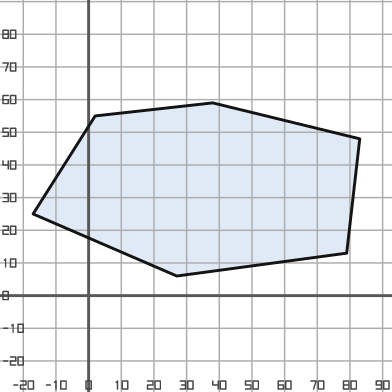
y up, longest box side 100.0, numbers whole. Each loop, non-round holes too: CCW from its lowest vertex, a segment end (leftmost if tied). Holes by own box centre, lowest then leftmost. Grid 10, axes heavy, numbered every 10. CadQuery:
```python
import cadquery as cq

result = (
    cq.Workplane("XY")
    .moveTo(27.0, 6.0)
    .lineTo(79.0, 13.0)
    .lineTo(83.0, 48.0)
    .lineTo(38.0, 59.0)
    .lineTo(2.0, 55.0)
    .lineTo(-17.0, 25.0)
    .close()
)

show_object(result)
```